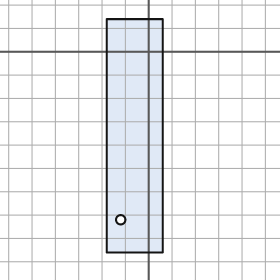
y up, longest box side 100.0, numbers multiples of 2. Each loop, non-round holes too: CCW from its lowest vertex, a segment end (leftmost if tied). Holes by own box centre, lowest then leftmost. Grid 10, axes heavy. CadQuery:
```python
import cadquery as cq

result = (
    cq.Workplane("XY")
    .moveTo(-18.0, -86.0)
    .lineTo(6.0, -86.0)
    .lineTo(6.0, 14.0)
    .lineTo(-18.0, 14.0)
    .close()
    .moveTo(-12.0, -72.0)
    .circle(2.0)
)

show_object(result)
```